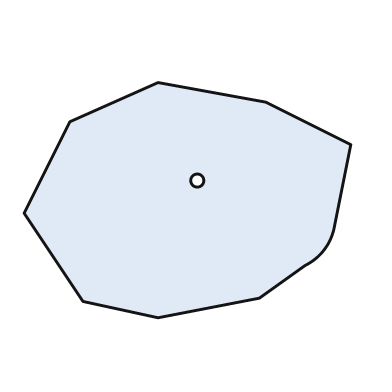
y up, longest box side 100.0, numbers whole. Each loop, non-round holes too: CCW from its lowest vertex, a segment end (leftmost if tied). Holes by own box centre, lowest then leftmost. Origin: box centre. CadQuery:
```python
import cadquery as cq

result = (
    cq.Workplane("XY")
    .moveTo(-9.0, -36.0)
    .lineTo(22.0, -30.0)
    .lineTo(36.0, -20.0)
    .threePointArc((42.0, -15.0), (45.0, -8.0))
    .lineTo(50.0, 17.0)
    .lineTo(24.0, 30.0)
    .lineTo(-9.0, 36.0)
    .lineTo(-36.0, 24.0)
    .lineTo(-50.0, -4.0)
    .lineTo(-32.0, -31.0)
    .close()
    .moveTo(3.0, 6.0)
    .circle(2.0)
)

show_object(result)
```